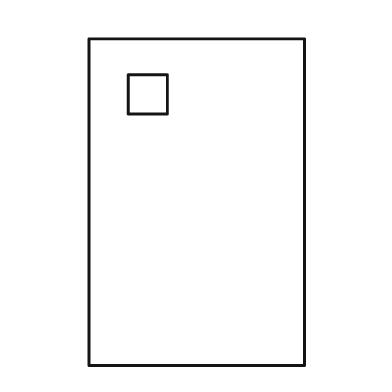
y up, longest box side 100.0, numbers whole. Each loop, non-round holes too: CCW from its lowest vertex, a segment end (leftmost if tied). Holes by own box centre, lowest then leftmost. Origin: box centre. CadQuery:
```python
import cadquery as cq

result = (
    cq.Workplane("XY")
    .moveTo(-33.0, -50.0)
    .lineTo(33.0, -50.0)
    .lineTo(33.0, 50.0)
    .lineTo(-33.0, 50.0)
    .close()
    .moveTo(-21.0, 27.0)
    .lineTo(-9.0, 27.0)
    .lineTo(-9.0, 39.0)
    .lineTo(-21.0, 39.0)
    .close()
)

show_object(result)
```